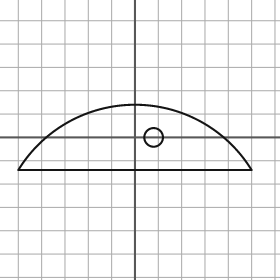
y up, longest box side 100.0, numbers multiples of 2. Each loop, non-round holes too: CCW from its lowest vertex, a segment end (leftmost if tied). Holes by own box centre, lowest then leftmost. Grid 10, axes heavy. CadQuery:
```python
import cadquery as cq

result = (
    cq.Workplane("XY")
    .moveTo(-50.0, -14.0)
    .lineTo(50.0, -14.0)
    .threePointArc((0.0, 14.0), (-50.0, -14.0))
    .close()
    .moveTo(8.0, 0.0)
    .circle(4.0)
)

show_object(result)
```